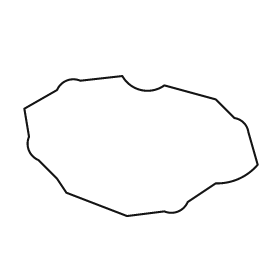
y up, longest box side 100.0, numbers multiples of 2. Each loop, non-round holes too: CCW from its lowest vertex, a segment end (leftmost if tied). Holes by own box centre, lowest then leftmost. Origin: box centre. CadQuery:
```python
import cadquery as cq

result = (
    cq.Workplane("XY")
    .moveTo(-6.0, -30.0)
    .lineTo(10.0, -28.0)
    .threePointArc((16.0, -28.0), (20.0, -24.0))
    .lineTo(32.0, -16.0)
    .threePointArc((42.0, -14.0), (50.0, -8.0))
    .lineTo(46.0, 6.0)
    .threePointArc((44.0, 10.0), (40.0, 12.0))
    .lineTo(32.0, 20.0)
    .lineTo(10.0, 26.0)
    .threePointArc((0.0, 24.0), (-8.0, 30.0))
    .lineTo(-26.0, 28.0)
    .threePointArc((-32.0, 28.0), (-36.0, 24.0))
    .lineTo(-50.0, 16.0)
    .lineTo(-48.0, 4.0)
    .threePointArc((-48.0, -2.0), (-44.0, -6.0))
    .lineTo(-36.0, -14.0)
    .lineTo(-32.0, -20.0)
    .close()
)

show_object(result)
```